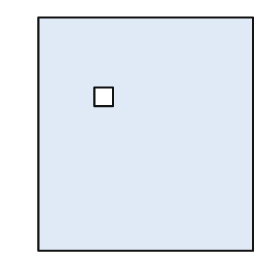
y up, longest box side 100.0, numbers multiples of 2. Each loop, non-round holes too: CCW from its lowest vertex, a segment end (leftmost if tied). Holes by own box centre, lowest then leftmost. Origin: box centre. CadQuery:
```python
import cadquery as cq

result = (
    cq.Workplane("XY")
    .moveTo(-46.0, -50.0)
    .lineTo(46.0, -50.0)
    .lineTo(46.0, 50.0)
    .lineTo(-46.0, 50.0)
    .close()
    .moveTo(-22.0, 12.0)
    .lineTo(-14.0, 12.0)
    .lineTo(-14.0, 20.0)
    .lineTo(-22.0, 20.0)
    .close()
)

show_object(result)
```